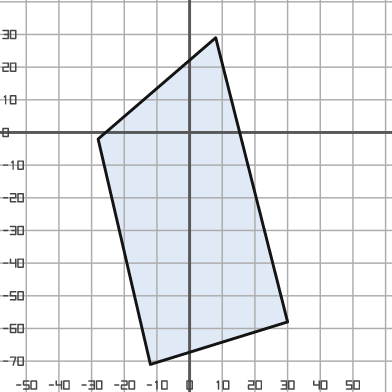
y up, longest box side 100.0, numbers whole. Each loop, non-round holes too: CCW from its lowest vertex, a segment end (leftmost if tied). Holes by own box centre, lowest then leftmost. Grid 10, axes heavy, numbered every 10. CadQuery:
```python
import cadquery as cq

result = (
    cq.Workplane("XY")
    .moveTo(-12.0, -71.0)
    .lineTo(30.0, -58.0)
    .lineTo(8.0, 29.0)
    .lineTo(-28.0, -2.0)
    .close()
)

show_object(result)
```